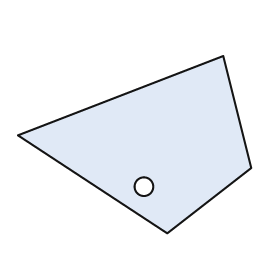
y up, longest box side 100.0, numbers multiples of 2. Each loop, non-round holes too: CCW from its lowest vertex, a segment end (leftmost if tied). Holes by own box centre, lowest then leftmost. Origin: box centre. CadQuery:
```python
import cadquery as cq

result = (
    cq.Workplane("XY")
    .moveTo(14.0, -38.0)
    .lineTo(50.0, -10.0)
    .lineTo(38.0, 38.0)
    .lineTo(-50.0, 4.0)
    .close()
    .moveTo(4.0, -18.0)
    .circle(4.0)
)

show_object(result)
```